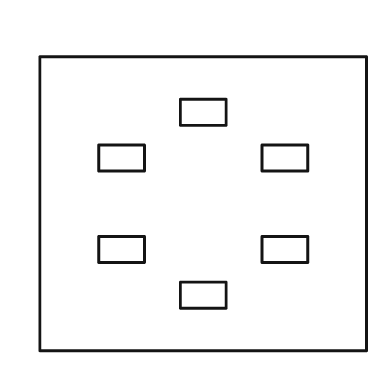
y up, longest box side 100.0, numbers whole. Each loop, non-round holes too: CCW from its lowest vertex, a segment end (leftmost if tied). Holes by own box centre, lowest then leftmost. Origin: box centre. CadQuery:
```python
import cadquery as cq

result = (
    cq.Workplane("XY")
    .moveTo(-50.0, -45.0)
    .lineTo(50.0, -45.0)
    .lineTo(50.0, 45.0)
    .lineTo(-50.0, 45.0)
    .close()
    .moveTo(-7.0, -32.0)
    .lineTo(7.0, -32.0)
    .lineTo(7.0, -24.0)
    .lineTo(-7.0, -24.0)
    .close()
    .moveTo(-32.0, -18.0)
    .lineTo(-18.0, -18.0)
    .lineTo(-18.0, -10.0)
    .lineTo(-32.0, -10.0)
    .close()
    .moveTo(18.0, -18.0)
    .lineTo(32.0, -18.0)
    .lineTo(32.0, -10.0)
    .lineTo(18.0, -10.0)
    .close()
    .moveTo(-32.0, 10.0)
    .lineTo(-18.0, 10.0)
    .lineTo(-18.0, 18.0)
    .lineTo(-32.0, 18.0)
    .close()
    .moveTo(18.0, 10.0)
    .lineTo(32.0, 10.0)
    .lineTo(32.0, 18.0)
    .lineTo(18.0, 18.0)
    .close()
    .moveTo(-7.0, 24.0)
    .lineTo(7.0, 24.0)
    .lineTo(7.0, 32.0)
    .lineTo(-7.0, 32.0)
    .close()
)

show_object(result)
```